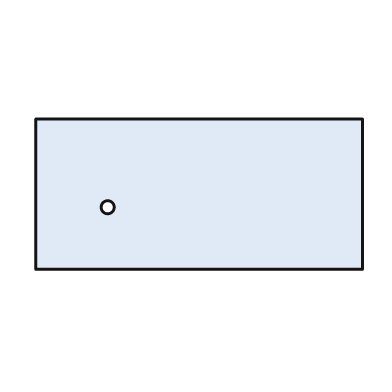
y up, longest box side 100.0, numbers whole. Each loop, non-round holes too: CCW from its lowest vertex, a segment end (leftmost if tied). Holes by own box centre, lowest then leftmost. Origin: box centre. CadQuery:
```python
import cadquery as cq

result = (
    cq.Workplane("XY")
    .moveTo(-50.0, -23.0)
    .lineTo(50.0, -23.0)
    .lineTo(50.0, 23.0)
    .lineTo(-50.0, 23.0)
    .close()
    .moveTo(-28.0, -4.0)
    .circle(2.0)
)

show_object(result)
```